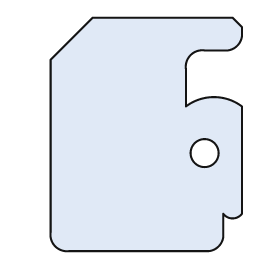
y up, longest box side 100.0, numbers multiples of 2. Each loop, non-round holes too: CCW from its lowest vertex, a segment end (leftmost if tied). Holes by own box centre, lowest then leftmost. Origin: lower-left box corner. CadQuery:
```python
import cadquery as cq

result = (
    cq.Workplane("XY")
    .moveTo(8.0, 0.0)
    .lineTo(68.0, 0.0)
    .threePointArc((72.0, 2.0), (74.0, 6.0))
    .lineTo(74.0, 16.0)
    .threePointArc((78.0, 14.0), (82.0, 16.0))
    .lineTo(82.0, 62.0)
    .threePointArc((70.0, 66.0), (58.0, 62.0))
    .lineTo(58.0, 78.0)
    .threePointArc((60.0, 84.0), (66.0, 86.0))
    .lineTo(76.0, 86.0)
    .threePointArc((80.0, 88.0), (82.0, 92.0))
    .lineTo(82.0, 96.0)
    .lineTo(78.0, 100.0)
    .lineTo(18.0, 100.0)
    .lineTo(0.0, 82.0)
    .lineTo(0.0, 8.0)
    .threePointArc((2.0, 2.0), (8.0, 0.0))
    .close()
    .moveTo(66.0, 42.0)
    .circle(6.0)
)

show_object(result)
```